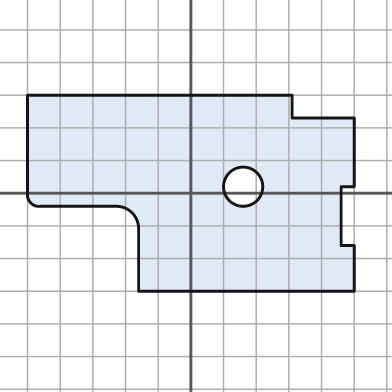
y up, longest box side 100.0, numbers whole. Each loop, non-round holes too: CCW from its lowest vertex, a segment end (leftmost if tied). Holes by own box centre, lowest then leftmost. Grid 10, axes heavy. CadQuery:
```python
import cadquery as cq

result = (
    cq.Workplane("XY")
    .moveTo(-16.0, -30.0)
    .lineTo(50.0, -30.0)
    .lineTo(50.0, -16.0)
    .lineTo(46.0, -16.0)
    .lineTo(46.0, 2.0)
    .lineTo(50.0, 2.0)
    .lineTo(50.0, 23.0)
    .lineTo(31.0, 23.0)
    .lineTo(31.0, 30.0)
    .lineTo(-50.0, 30.0)
    .lineTo(-50.0, 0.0)
    .threePointArc((-49.0, -3.0), (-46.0, -4.0))
    .lineTo(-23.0, -4.0)
    .threePointArc((-18.0, -6.0), (-16.0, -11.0))
    .close()
    .moveTo(16.0, 2.0)
    .circle(6.0)
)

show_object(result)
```